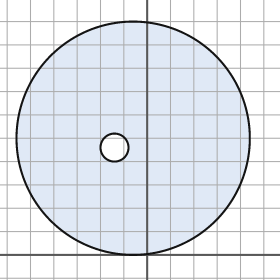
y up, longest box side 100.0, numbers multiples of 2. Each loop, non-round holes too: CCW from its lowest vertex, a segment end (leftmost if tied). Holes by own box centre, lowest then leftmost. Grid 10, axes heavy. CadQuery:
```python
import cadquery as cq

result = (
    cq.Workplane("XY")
    .moveTo(-6.0, 50.0)
    .circle(50.0)
    .moveTo(-14.0, 46.0)
    .circle(6.0)
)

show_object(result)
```